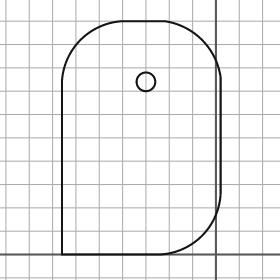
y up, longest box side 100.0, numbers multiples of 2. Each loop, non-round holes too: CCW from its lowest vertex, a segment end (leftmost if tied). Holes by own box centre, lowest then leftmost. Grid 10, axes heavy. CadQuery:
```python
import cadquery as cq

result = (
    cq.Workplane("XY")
    .moveTo(-66.0, 0.0)
    .lineTo(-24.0, 0.0)
    .threePointArc((-6.0, 8.0), (2.0, 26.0))
    .lineTo(2.0, 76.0)
    .threePointArc((-6.0, 92.0), (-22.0, 100.0))
    .lineTo(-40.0, 100.0)
    .threePointArc((-58.0, 92.0), (-66.0, 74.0))
    .close()
    .moveTo(-30.0, 74.0)
    .circle(4.0)
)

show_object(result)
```